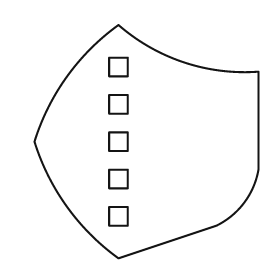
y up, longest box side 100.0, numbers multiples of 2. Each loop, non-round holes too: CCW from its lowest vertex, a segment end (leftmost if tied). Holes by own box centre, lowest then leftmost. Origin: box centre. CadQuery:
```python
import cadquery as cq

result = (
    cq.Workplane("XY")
    .moveTo(-12.0, -50.0)
    .lineTo(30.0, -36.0)
    .threePointArc((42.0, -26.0), (48.0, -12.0))
    .lineTo(48.0, 30.0)
    .threePointArc((16.0, 34.0), (-12.0, 50.0))
    .threePointArc((-34.0, 28.0), (-48.0, 0.0))
    .threePointArc((-34.0, -28.0), (-12.0, -50.0))
    .close()
    .moveTo(-16.0, -36.0)
    .lineTo(-8.0, -36.0)
    .lineTo(-8.0, -28.0)
    .lineTo(-16.0, -28.0)
    .close()
    .moveTo(-16.0, -20.0)
    .lineTo(-8.0, -20.0)
    .lineTo(-8.0, -12.0)
    .lineTo(-16.0, -12.0)
    .close()
    .moveTo(-16.0, -4.0)
    .lineTo(-8.0, -4.0)
    .lineTo(-8.0, 4.0)
    .lineTo(-16.0, 4.0)
    .close()
    .moveTo(-16.0, 12.0)
    .lineTo(-8.0, 12.0)
    .lineTo(-8.0, 20.0)
    .lineTo(-16.0, 20.0)
    .close()
    .moveTo(-16.0, 28.0)
    .lineTo(-8.0, 28.0)
    .lineTo(-8.0, 36.0)
    .lineTo(-16.0, 36.0)
    .close()
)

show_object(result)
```